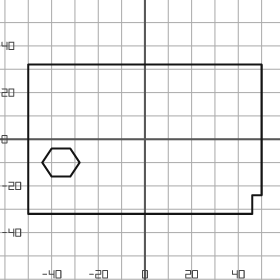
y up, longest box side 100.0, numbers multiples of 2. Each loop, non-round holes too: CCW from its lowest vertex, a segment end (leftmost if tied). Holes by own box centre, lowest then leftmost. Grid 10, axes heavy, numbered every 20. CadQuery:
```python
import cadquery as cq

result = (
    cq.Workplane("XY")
    .moveTo(-50.0, -32.0)
    .lineTo(46.0, -32.0)
    .lineTo(46.0, -24.0)
    .lineTo(50.0, -24.0)
    .lineTo(50.0, 32.0)
    .lineTo(-50.0, 32.0)
    .close()
    .moveTo(-40.0, -16.0)
    .lineTo(-32.0, -16.0)
    .lineTo(-28.0, -10.0)
    .lineTo(-32.0, -4.0)
    .lineTo(-40.0, -4.0)
    .lineTo(-44.0, -10.0)
    .close()
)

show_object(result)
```